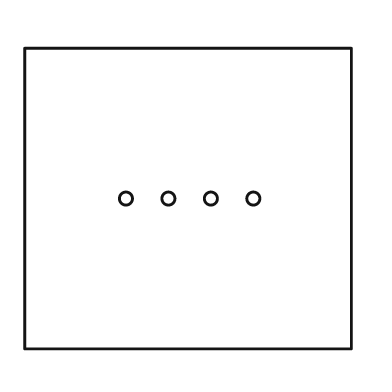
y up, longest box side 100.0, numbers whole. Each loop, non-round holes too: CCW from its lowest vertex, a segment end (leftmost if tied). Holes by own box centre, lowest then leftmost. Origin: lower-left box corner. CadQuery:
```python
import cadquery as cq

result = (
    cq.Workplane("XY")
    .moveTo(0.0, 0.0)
    .lineTo(100.0, 0.0)
    .lineTo(100.0, 92.0)
    .lineTo(0.0, 92.0)
    .close()
    .moveTo(31.0, 46.0)
    .circle(2.0)
    .moveTo(44.0, 46.0)
    .circle(2.0)
    .moveTo(57.0, 46.0)
    .circle(2.0)
    .moveTo(70.0, 46.0)
    .circle(2.0)
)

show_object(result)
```